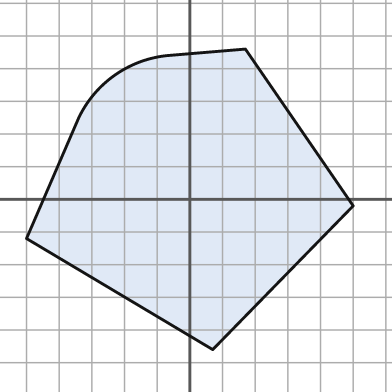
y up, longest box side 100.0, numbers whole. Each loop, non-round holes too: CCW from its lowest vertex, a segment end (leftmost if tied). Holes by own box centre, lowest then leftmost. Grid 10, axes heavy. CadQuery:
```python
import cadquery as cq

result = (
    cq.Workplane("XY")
    .moveTo(7.0, -46.0)
    .lineTo(50.0, -2.0)
    .lineTo(17.0, 46.0)
    .lineTo(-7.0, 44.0)
    .threePointArc((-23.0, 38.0), (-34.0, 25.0))
    .lineTo(-50.0, -12.0)
    .close()
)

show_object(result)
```